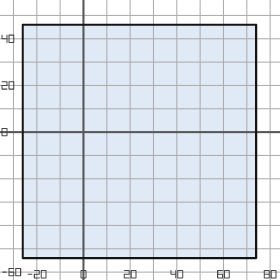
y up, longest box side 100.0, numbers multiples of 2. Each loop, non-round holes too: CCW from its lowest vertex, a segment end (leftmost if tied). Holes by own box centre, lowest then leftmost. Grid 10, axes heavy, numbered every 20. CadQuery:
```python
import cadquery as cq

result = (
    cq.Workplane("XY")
    .moveTo(-26.0, -54.0)
    .lineTo(74.0, -54.0)
    .lineTo(74.0, 46.0)
    .lineTo(-26.0, 46.0)
    .close()
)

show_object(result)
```